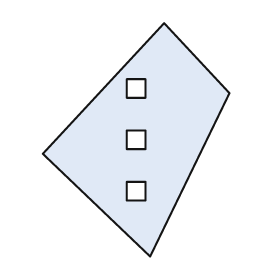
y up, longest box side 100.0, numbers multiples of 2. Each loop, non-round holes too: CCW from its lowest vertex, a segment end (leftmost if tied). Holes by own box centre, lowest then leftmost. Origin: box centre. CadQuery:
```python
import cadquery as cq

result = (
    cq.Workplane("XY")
    .moveTo(6.0, -50.0)
    .lineTo(40.0, 20.0)
    .lineTo(12.0, 50.0)
    .lineTo(-40.0, -6.0)
    .close()
    .moveTo(-4.0, -26.0)
    .lineTo(4.0, -26.0)
    .lineTo(4.0, -18.0)
    .lineTo(-4.0, -18.0)
    .close()
    .moveTo(-4.0, -4.0)
    .lineTo(4.0, -4.0)
    .lineTo(4.0, 4.0)
    .lineTo(-4.0, 4.0)
    .close()
    .moveTo(-4.0, 18.0)
    .lineTo(4.0, 18.0)
    .lineTo(4.0, 26.0)
    .lineTo(-4.0, 26.0)
    .close()
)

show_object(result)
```